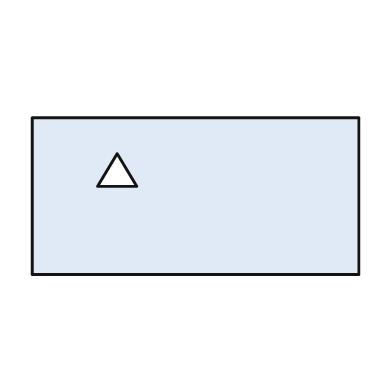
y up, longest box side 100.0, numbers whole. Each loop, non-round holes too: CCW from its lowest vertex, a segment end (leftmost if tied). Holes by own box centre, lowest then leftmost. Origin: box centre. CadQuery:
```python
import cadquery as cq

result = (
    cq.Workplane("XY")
    .moveTo(-50.0, -24.0)
    .lineTo(50.0, -24.0)
    .lineTo(50.0, 24.0)
    .lineTo(-50.0, 24.0)
    .close()
    .moveTo(-30.0, 3.0)
    .lineTo(-18.0, 3.0)
    .lineTo(-24.0, 13.0)
    .close()
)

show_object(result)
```